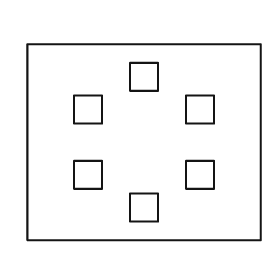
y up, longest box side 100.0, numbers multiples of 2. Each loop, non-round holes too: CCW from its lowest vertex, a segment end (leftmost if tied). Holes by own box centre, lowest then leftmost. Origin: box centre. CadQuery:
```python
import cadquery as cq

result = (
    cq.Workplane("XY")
    .moveTo(-50.0, -42.0)
    .lineTo(50.0, -42.0)
    .lineTo(50.0, 42.0)
    .lineTo(-50.0, 42.0)
    .close()
    .moveTo(-6.0, -34.0)
    .lineTo(6.0, -34.0)
    .lineTo(6.0, -22.0)
    .lineTo(-6.0, -22.0)
    .close()
    .moveTo(-30.0, -20.0)
    .lineTo(-18.0, -20.0)
    .lineTo(-18.0, -8.0)
    .lineTo(-30.0, -8.0)
    .close()
    .moveTo(18.0, -20.0)
    .lineTo(30.0, -20.0)
    .lineTo(30.0, -8.0)
    .lineTo(18.0, -8.0)
    .close()
    .moveTo(-30.0, 8.0)
    .lineTo(-18.0, 8.0)
    .lineTo(-18.0, 20.0)
    .lineTo(-30.0, 20.0)
    .close()
    .moveTo(18.0, 8.0)
    .lineTo(30.0, 8.0)
    .lineTo(30.0, 20.0)
    .lineTo(18.0, 20.0)
    .close()
    .moveTo(-6.0, 22.0)
    .lineTo(6.0, 22.0)
    .lineTo(6.0, 34.0)
    .lineTo(-6.0, 34.0)
    .close()
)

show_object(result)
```